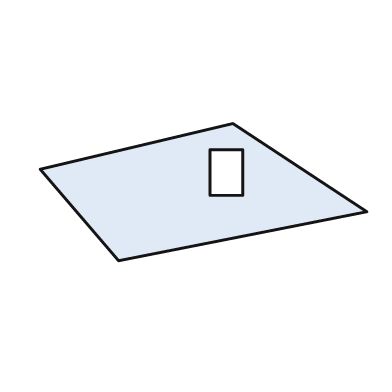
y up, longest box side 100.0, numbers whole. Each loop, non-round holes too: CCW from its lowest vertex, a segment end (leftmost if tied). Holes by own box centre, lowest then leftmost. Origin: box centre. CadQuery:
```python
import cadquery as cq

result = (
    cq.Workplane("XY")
    .moveTo(-26.0, -21.0)
    .lineTo(50.0, -6.0)
    .lineTo(9.0, 21.0)
    .lineTo(-50.0, 7.0)
    .close()
    .moveTo(2.0, -1.0)
    .lineTo(12.0, -1.0)
    .lineTo(12.0, 13.0)
    .lineTo(2.0, 13.0)
    .close()
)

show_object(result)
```